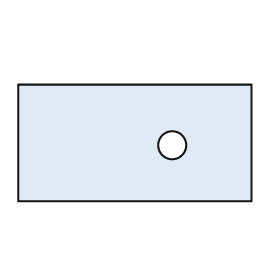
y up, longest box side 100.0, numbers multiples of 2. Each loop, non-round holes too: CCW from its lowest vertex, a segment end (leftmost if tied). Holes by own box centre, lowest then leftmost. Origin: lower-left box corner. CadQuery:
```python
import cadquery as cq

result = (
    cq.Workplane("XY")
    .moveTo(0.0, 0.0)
    .lineTo(100.0, 0.0)
    .lineTo(100.0, 50.0)
    .lineTo(0.0, 50.0)
    .close()
    .moveTo(66.0, 24.0)
    .circle(6.0)
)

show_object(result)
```